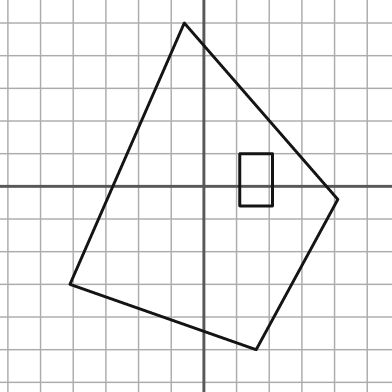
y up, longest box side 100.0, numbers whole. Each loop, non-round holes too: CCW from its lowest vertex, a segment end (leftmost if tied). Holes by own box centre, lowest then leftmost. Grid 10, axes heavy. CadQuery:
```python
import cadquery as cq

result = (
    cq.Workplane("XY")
    .moveTo(16.0, -50.0)
    .lineTo(41.0, -4.0)
    .lineTo(-6.0, 50.0)
    .lineTo(-41.0, -30.0)
    .close()
    .moveTo(11.0, -6.0)
    .lineTo(21.0, -6.0)
    .lineTo(21.0, 10.0)
    .lineTo(11.0, 10.0)
    .close()
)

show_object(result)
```